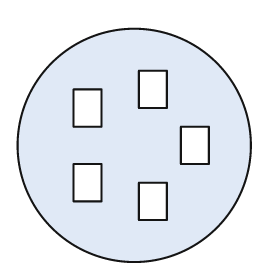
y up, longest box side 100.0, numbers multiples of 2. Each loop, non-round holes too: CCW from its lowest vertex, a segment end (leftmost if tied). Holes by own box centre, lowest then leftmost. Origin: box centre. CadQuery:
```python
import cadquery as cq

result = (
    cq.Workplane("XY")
    .moveTo(0.0, 0.0)
    .circle(50.0)
    .moveTo(2.0, -32.0)
    .lineTo(14.0, -32.0)
    .lineTo(14.0, -16.0)
    .lineTo(2.0, -16.0)
    .close()
    .moveTo(-26.0, -24.0)
    .lineTo(-14.0, -24.0)
    .lineTo(-14.0, -8.0)
    .lineTo(-26.0, -8.0)
    .close()
    .moveTo(20.0, -8.0)
    .lineTo(32.0, -8.0)
    .lineTo(32.0, 8.0)
    .lineTo(20.0, 8.0)
    .close()
    .moveTo(-26.0, 8.0)
    .lineTo(-14.0, 8.0)
    .lineTo(-14.0, 24.0)
    .lineTo(-26.0, 24.0)
    .close()
    .moveTo(2.0, 16.0)
    .lineTo(14.0, 16.0)
    .lineTo(14.0, 32.0)
    .lineTo(2.0, 32.0)
    .close()
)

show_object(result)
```